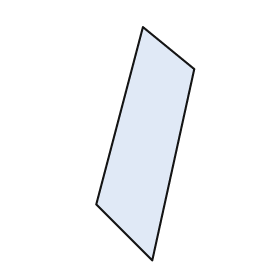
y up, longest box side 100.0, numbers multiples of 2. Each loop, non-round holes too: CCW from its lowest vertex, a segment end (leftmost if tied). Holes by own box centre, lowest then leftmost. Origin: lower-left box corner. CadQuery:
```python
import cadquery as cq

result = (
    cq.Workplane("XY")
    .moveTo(24.0, 0.0)
    .lineTo(42.0, 82.0)
    .lineTo(20.0, 100.0)
    .lineTo(0.0, 24.0)
    .close()
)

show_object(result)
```